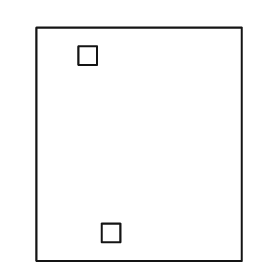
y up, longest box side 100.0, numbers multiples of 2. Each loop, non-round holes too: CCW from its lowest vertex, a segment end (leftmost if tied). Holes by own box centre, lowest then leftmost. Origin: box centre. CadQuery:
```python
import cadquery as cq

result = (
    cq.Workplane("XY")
    .moveTo(-44.0, -50.0)
    .lineTo(44.0, -50.0)
    .lineTo(44.0, 50.0)
    .lineTo(-44.0, 50.0)
    .close()
    .moveTo(-16.0, -42.0)
    .lineTo(-8.0, -42.0)
    .lineTo(-8.0, -34.0)
    .lineTo(-16.0, -34.0)
    .close()
    .moveTo(-26.0, 34.0)
    .lineTo(-18.0, 34.0)
    .lineTo(-18.0, 42.0)
    .lineTo(-26.0, 42.0)
    .close()
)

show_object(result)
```